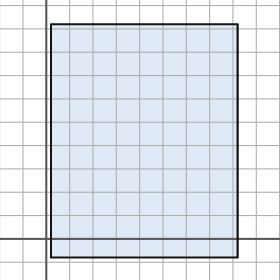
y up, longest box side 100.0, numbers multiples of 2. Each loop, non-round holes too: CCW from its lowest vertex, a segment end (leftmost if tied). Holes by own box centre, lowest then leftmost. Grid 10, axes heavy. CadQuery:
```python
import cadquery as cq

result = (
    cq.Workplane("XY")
    .moveTo(2.0, -8.0)
    .lineTo(82.0, -8.0)
    .lineTo(82.0, 92.0)
    .lineTo(2.0, 92.0)
    .close()
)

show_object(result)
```